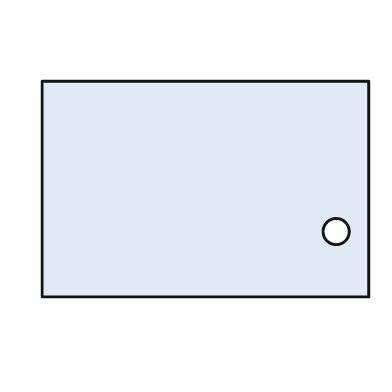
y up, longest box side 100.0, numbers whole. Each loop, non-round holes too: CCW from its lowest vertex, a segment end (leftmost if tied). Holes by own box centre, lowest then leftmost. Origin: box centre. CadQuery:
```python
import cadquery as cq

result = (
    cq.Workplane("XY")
    .moveTo(-50.0, -33.0)
    .lineTo(50.0, -33.0)
    .lineTo(50.0, 33.0)
    .lineTo(-50.0, 33.0)
    .close()
    .moveTo(40.0, -13.0)
    .circle(4.0)
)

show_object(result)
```